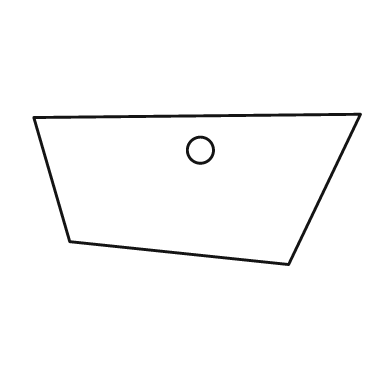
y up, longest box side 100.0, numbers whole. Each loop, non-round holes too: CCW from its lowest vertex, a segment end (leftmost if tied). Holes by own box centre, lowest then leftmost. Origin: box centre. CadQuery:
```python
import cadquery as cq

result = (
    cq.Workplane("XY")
    .moveTo(28.0, -23.0)
    .lineTo(50.0, 23.0)
    .lineTo(-50.0, 22.0)
    .lineTo(-39.0, -16.0)
    .close()
    .moveTo(1.0, 12.0)
    .circle(4.0)
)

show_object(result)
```